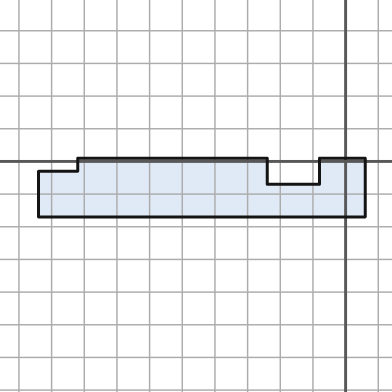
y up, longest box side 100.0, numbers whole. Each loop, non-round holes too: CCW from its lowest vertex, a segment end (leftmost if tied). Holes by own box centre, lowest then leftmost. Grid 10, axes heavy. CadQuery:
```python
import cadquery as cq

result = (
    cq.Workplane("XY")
    .moveTo(-94.0, -17.0)
    .lineTo(6.0, -17.0)
    .lineTo(6.0, 1.0)
    .lineTo(-8.0, 1.0)
    .lineTo(-8.0, -7.0)
    .lineTo(-24.0, -7.0)
    .lineTo(-24.0, 1.0)
    .lineTo(-82.0, 1.0)
    .lineTo(-82.0, -3.0)
    .lineTo(-94.0, -3.0)
    .close()
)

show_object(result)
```